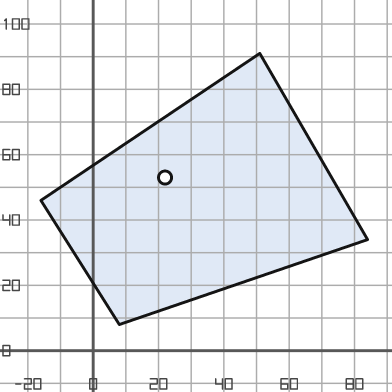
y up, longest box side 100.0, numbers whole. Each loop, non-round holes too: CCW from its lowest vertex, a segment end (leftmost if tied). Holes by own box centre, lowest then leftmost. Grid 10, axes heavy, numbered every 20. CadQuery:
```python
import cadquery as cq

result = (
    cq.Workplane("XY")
    .moveTo(8.0, 8.0)
    .lineTo(84.0, 34.0)
    .lineTo(51.0, 91.0)
    .lineTo(-16.0, 46.0)
    .close()
    .moveTo(22.0, 53.0)
    .circle(2.0)
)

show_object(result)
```